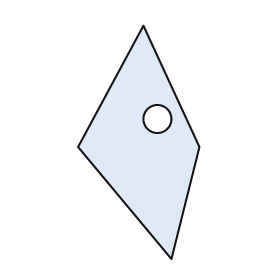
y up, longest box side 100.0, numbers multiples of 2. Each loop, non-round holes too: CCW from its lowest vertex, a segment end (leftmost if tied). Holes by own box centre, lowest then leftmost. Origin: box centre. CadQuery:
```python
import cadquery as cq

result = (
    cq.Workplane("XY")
    .moveTo(14.0, -50.0)
    .lineTo(26.0, -2.0)
    .lineTo(2.0, 50.0)
    .lineTo(-26.0, -2.0)
    .close()
    .moveTo(8.0, 10.0)
    .circle(6.0)
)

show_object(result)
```